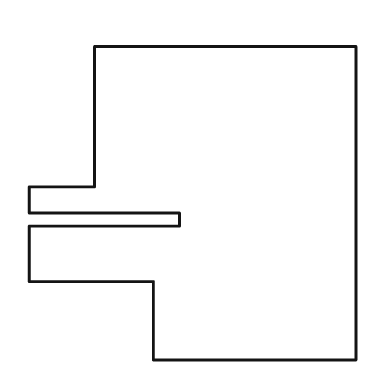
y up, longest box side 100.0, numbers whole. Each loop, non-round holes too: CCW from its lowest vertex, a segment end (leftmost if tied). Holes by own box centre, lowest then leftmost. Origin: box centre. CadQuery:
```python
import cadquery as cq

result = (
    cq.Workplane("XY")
    .moveTo(-12.0, -48.0)
    .lineTo(50.0, -48.0)
    .lineTo(50.0, 48.0)
    .lineTo(-30.0, 48.0)
    .lineTo(-30.0, 5.0)
    .lineTo(-50.0, 5.0)
    .lineTo(-50.0, -3.0)
    .lineTo(-4.0, -3.0)
    .lineTo(-4.0, -7.0)
    .lineTo(-50.0, -7.0)
    .lineTo(-50.0, -24.0)
    .lineTo(-12.0, -24.0)
    .close()
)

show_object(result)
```